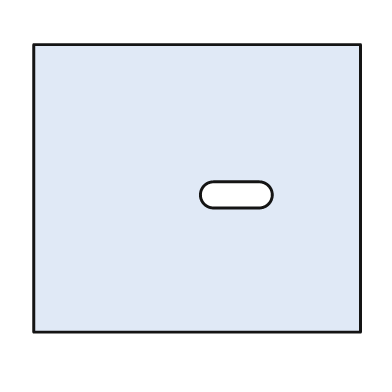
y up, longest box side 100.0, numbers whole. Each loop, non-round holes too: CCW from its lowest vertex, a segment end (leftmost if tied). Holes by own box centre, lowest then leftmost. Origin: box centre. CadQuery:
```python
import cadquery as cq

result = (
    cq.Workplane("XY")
    .moveTo(-50.0, -44.0)
    .lineTo(50.0, -44.0)
    .lineTo(50.0, 44.0)
    .lineTo(-50.0, 44.0)
    .close()
    .moveTo(5.0, -6.0)
    .lineTo(19.0, -6.0)
    .threePointArc((23.0, -2.0), (19.0, 2.0))
    .lineTo(5.0, 2.0)
    .threePointArc((1.0, -2.0), (5.0, -6.0))
    .close()
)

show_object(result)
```